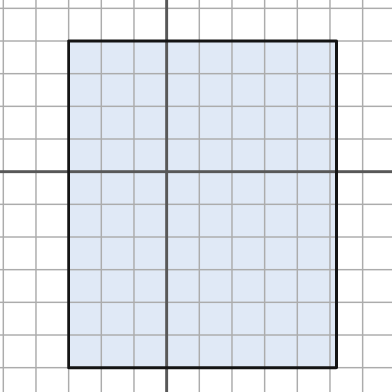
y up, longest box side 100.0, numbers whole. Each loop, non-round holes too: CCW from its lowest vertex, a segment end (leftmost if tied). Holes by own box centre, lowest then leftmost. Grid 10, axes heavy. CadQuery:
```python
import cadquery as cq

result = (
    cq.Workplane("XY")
    .moveTo(-30.0, -60.0)
    .lineTo(52.0, -60.0)
    .lineTo(52.0, 40.0)
    .lineTo(-30.0, 40.0)
    .close()
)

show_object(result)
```